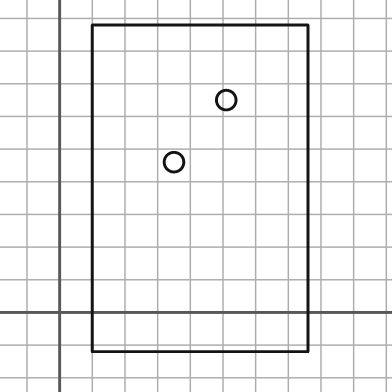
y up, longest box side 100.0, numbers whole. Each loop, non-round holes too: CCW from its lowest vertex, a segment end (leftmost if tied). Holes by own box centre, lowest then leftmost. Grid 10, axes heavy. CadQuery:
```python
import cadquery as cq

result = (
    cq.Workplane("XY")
    .moveTo(10.0, -12.0)
    .lineTo(76.0, -12.0)
    .lineTo(76.0, 88.0)
    .lineTo(10.0, 88.0)
    .close()
    .moveTo(35.0, 46.0)
    .circle(3.0)
    .moveTo(51.0, 65.0)
    .circle(3.0)
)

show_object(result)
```